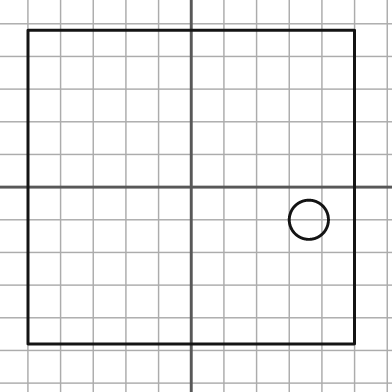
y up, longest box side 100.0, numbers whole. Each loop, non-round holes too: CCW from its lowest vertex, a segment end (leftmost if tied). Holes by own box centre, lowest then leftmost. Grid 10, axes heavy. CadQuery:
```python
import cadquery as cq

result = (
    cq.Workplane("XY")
    .moveTo(-50.0, -48.0)
    .lineTo(50.0, -48.0)
    .lineTo(50.0, 48.0)
    .lineTo(-50.0, 48.0)
    .close()
    .moveTo(36.0, -10.0)
    .circle(6.0)
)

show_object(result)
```